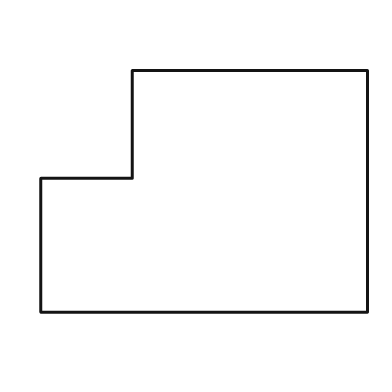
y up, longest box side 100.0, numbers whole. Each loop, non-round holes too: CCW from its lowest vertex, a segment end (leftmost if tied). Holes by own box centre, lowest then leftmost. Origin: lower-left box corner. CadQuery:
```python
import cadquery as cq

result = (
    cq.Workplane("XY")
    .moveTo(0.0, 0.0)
    .lineTo(100.0, 0.0)
    .lineTo(100.0, 74.0)
    .lineTo(28.0, 74.0)
    .lineTo(28.0, 41.0)
    .lineTo(0.0, 41.0)
    .close()
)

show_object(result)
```